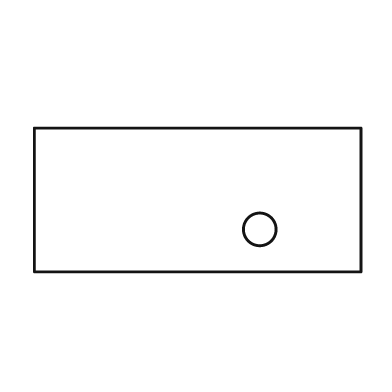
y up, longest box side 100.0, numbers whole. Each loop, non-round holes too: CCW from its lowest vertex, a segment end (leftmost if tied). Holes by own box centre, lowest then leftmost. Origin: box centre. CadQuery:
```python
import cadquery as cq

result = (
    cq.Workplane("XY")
    .moveTo(-50.0, -22.0)
    .lineTo(50.0, -22.0)
    .lineTo(50.0, 22.0)
    .lineTo(-50.0, 22.0)
    .close()
    .moveTo(19.0, -9.0)
    .circle(5.0)
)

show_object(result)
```